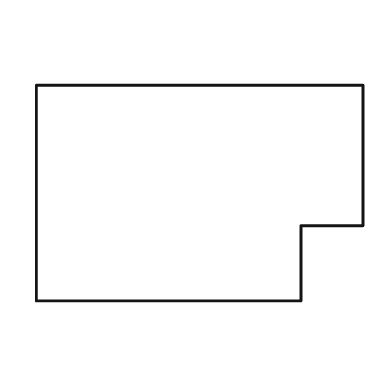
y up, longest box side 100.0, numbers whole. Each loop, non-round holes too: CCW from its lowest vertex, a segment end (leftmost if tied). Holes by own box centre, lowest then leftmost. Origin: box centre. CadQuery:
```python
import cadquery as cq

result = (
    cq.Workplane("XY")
    .moveTo(-50.0, -33.0)
    .lineTo(31.0, -33.0)
    .lineTo(31.0, -10.0)
    .lineTo(50.0, -10.0)
    .lineTo(50.0, 33.0)
    .lineTo(-50.0, 33.0)
    .close()
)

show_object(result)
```